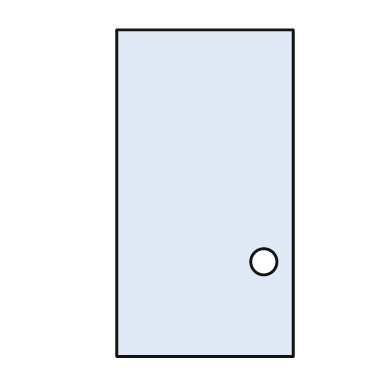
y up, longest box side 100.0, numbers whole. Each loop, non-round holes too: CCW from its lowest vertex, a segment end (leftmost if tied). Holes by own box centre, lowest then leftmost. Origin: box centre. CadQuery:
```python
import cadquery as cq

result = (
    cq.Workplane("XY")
    .moveTo(-27.0, -50.0)
    .lineTo(27.0, -50.0)
    .lineTo(27.0, 50.0)
    .lineTo(-27.0, 50.0)
    .close()
    .moveTo(18.0, -21.0)
    .circle(4.0)
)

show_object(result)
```